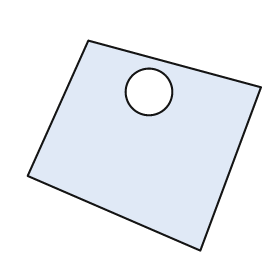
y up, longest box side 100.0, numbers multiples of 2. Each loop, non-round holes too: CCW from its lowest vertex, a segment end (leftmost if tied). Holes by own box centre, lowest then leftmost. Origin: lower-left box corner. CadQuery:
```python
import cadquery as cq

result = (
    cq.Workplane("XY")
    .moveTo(74.0, 0.0)
    .lineTo(100.0, 70.0)
    .lineTo(26.0, 90.0)
    .lineTo(0.0, 32.0)
    .close()
    .moveTo(52.0, 68.0)
    .circle(10.0)
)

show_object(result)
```